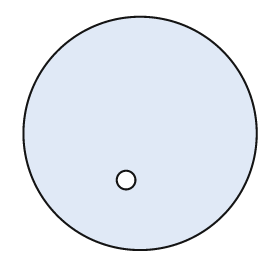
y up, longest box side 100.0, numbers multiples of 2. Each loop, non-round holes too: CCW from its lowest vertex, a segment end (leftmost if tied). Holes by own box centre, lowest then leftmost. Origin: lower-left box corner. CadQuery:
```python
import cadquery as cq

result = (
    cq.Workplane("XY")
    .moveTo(50.0, 50.0)
    .circle(50.0)
    .moveTo(44.0, 30.0)
    .circle(4.0)
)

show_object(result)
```